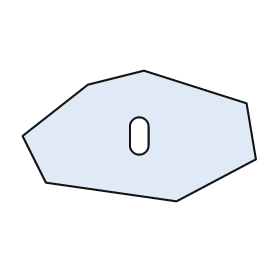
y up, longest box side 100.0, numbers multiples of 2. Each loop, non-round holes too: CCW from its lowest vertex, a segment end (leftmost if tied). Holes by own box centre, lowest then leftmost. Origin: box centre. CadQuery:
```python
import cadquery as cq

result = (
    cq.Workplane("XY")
    .moveTo(16.0, -28.0)
    .lineTo(50.0, -10.0)
    .lineTo(46.0, 14.0)
    .lineTo(2.0, 28.0)
    .lineTo(-22.0, 22.0)
    .lineTo(-50.0, 0.0)
    .lineTo(-40.0, -20.0)
    .close()
    .moveTo(-4.0, -4.0)
    .threePointArc((0.0, -8.0), (4.0, -4.0))
    .lineTo(4.0, 4.0)
    .threePointArc((0.0, 8.0), (-4.0, 4.0))
    .close()
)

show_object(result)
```